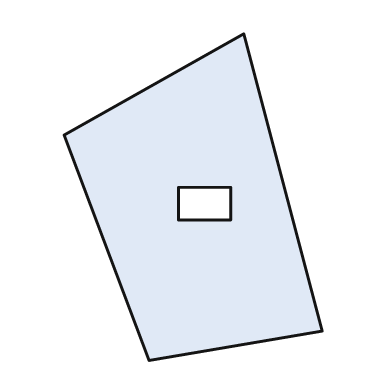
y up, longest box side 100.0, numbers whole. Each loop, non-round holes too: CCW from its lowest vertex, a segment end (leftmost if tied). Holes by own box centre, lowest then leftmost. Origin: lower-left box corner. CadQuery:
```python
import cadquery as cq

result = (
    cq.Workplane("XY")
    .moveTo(26.0, 0.0)
    .lineTo(79.0, 9.0)
    .lineTo(55.0, 100.0)
    .lineTo(0.0, 69.0)
    .close()
    .moveTo(35.0, 43.0)
    .lineTo(51.0, 43.0)
    .lineTo(51.0, 53.0)
    .lineTo(35.0, 53.0)
    .close()
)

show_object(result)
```